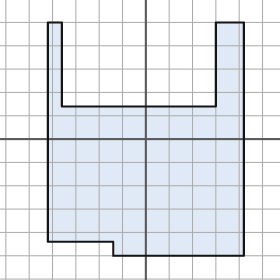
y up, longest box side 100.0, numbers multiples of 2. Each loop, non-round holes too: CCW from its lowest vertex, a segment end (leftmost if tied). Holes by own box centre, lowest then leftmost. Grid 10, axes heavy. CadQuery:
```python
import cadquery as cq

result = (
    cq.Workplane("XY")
    .moveTo(-14.0, -50.0)
    .lineTo(42.0, -50.0)
    .lineTo(42.0, 50.0)
    .lineTo(30.0, 50.0)
    .lineTo(30.0, 14.0)
    .lineTo(-36.0, 14.0)
    .lineTo(-36.0, 50.0)
    .lineTo(-42.0, 50.0)
    .lineTo(-42.0, -44.0)
    .lineTo(-14.0, -44.0)
    .close()
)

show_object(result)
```